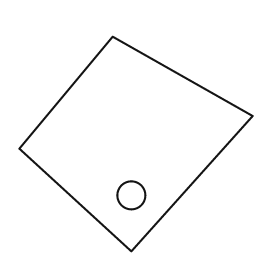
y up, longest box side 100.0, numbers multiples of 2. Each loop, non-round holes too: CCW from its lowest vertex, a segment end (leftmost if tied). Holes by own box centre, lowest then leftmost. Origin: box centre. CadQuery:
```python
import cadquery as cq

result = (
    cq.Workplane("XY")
    .moveTo(-2.0, -46.0)
    .lineTo(50.0, 12.0)
    .lineTo(-10.0, 46.0)
    .lineTo(-50.0, -2.0)
    .close()
    .moveTo(-2.0, -22.0)
    .circle(6.0)
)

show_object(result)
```